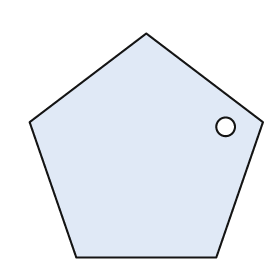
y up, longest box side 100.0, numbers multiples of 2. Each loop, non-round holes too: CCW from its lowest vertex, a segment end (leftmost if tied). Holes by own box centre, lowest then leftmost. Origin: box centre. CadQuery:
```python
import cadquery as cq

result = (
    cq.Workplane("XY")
    .moveTo(-30.0, -48.0)
    .lineTo(30.0, -48.0)
    .lineTo(50.0, 10.0)
    .lineTo(0.0, 48.0)
    .lineTo(-50.0, 10.0)
    .close()
    .moveTo(34.0, 8.0)
    .circle(4.0)
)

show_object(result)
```